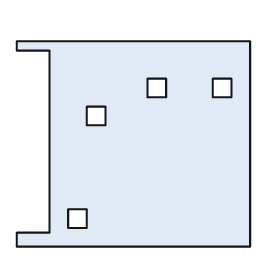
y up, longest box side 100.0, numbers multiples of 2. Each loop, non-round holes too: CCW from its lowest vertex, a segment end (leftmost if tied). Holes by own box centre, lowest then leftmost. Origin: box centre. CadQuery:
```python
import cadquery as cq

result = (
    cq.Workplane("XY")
    .moveTo(-50.0, -44.0)
    .lineTo(50.0, -44.0)
    .lineTo(50.0, 44.0)
    .lineTo(-50.0, 44.0)
    .lineTo(-50.0, 40.0)
    .lineTo(-36.0, 40.0)
    .lineTo(-36.0, -38.0)
    .lineTo(-50.0, -38.0)
    .close()
    .moveTo(-28.0, -36.0)
    .lineTo(-20.0, -36.0)
    .lineTo(-20.0, -28.0)
    .lineTo(-28.0, -28.0)
    .close()
    .moveTo(-20.0, 8.0)
    .lineTo(-12.0, 8.0)
    .lineTo(-12.0, 16.0)
    .lineTo(-20.0, 16.0)
    .close()
    .moveTo(6.0, 20.0)
    .lineTo(14.0, 20.0)
    .lineTo(14.0, 28.0)
    .lineTo(6.0, 28.0)
    .close()
    .moveTo(34.0, 20.0)
    .lineTo(42.0, 20.0)
    .lineTo(42.0, 28.0)
    .lineTo(34.0, 28.0)
    .close()
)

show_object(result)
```